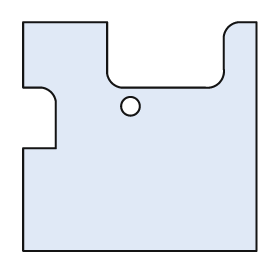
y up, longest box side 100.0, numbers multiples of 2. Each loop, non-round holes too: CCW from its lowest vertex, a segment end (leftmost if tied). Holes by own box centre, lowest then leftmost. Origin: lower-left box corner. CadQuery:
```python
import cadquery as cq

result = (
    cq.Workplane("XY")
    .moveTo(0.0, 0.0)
    .lineTo(100.0, 0.0)
    .lineTo(100.0, 98.0)
    .lineTo(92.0, 98.0)
    .threePointArc((88.0, 96.0), (86.0, 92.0))
    .lineTo(86.0, 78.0)
    .threePointArc((84.0, 72.0), (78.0, 70.0))
    .lineTo(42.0, 70.0)
    .threePointArc((38.0, 72.0), (36.0, 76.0))
    .lineTo(36.0, 98.0)
    .lineTo(0.0, 98.0)
    .lineTo(0.0, 70.0)
    .lineTo(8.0, 70.0)
    .threePointArc((12.0, 68.0), (14.0, 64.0))
    .lineTo(14.0, 44.0)
    .lineTo(0.0, 44.0)
    .close()
    .moveTo(46.0, 62.0)
    .circle(4.0)
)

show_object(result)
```